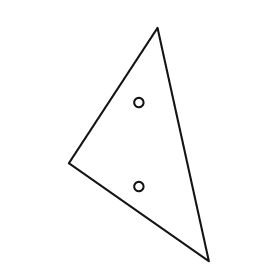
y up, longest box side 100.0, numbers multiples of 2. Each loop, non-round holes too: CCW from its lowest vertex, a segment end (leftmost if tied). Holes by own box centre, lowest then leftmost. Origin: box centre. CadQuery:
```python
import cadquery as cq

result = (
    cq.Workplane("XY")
    .moveTo(30.0, -50.0)
    .lineTo(8.0, 50.0)
    .lineTo(-30.0, -8.0)
    .close()
    .moveTo(0.0, -18.0)
    .circle(2.0)
    .moveTo(0.0, 18.0)
    .circle(2.0)
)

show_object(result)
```